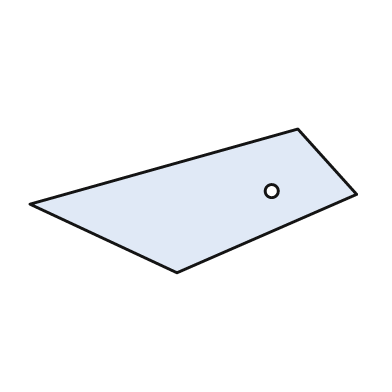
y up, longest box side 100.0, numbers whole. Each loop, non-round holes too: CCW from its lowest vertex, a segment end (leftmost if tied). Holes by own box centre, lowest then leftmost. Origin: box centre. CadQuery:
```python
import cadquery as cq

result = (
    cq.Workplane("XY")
    .moveTo(-5.0, -22.0)
    .lineTo(50.0, 2.0)
    .lineTo(32.0, 22.0)
    .lineTo(-50.0, -1.0)
    .close()
    .moveTo(24.0, 3.0)
    .circle(2.0)
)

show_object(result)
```